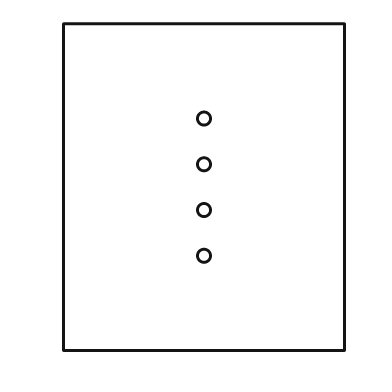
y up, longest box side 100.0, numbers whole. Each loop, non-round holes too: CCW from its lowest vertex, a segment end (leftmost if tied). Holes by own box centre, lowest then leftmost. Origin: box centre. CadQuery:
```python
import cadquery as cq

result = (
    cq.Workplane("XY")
    .moveTo(-43.0, -50.0)
    .lineTo(43.0, -50.0)
    .lineTo(43.0, 50.0)
    .lineTo(-43.0, 50.0)
    .close()
    .moveTo(0.0, -21.0)
    .circle(2.0)
    .moveTo(0.0, -7.0)
    .circle(2.0)
    .moveTo(0.0, 7.0)
    .circle(2.0)
    .moveTo(0.0, 21.0)
    .circle(2.0)
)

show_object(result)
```